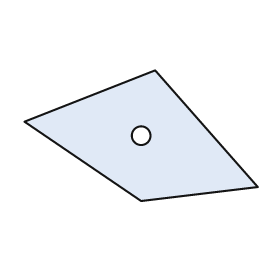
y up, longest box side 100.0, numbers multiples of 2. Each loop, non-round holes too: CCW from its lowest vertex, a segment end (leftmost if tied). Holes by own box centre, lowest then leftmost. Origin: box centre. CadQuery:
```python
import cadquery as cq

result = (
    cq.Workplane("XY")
    .moveTo(0.0, -28.0)
    .lineTo(50.0, -22.0)
    .lineTo(6.0, 28.0)
    .lineTo(-50.0, 6.0)
    .close()
    .moveTo(0.0, 0.0)
    .circle(4.0)
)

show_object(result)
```